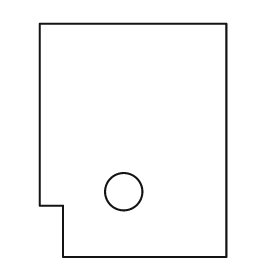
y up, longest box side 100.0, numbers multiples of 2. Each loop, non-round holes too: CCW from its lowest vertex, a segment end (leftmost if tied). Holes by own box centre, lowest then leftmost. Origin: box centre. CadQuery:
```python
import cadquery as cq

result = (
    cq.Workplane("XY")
    .moveTo(-30.0, -50.0)
    .lineTo(40.0, -50.0)
    .lineTo(40.0, 50.0)
    .lineTo(-40.0, 50.0)
    .lineTo(-40.0, -28.0)
    .lineTo(-30.0, -28.0)
    .close()
    .moveTo(-4.0, -22.0)
    .circle(8.0)
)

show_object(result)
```